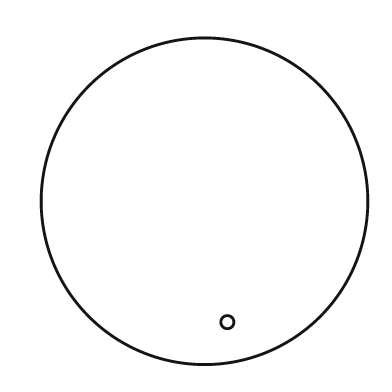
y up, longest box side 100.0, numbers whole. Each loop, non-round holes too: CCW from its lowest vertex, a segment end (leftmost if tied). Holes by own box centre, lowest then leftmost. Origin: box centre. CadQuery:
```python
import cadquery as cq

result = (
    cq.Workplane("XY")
    .moveTo(0.0, 0.0)
    .circle(50.0)
    .moveTo(7.0, -37.0)
    .circle(2.0)
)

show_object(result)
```